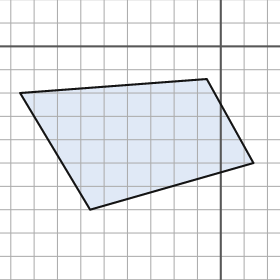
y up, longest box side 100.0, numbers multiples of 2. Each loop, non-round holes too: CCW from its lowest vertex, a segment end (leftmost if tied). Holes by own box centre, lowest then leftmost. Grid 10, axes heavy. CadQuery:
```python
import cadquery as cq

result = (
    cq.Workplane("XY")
    .moveTo(-56.0, -70.0)
    .lineTo(14.0, -50.0)
    .lineTo(-6.0, -14.0)
    .lineTo(-86.0, -20.0)
    .close()
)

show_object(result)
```